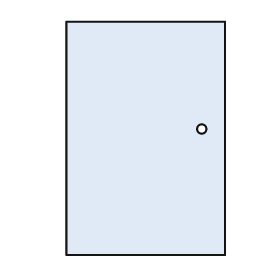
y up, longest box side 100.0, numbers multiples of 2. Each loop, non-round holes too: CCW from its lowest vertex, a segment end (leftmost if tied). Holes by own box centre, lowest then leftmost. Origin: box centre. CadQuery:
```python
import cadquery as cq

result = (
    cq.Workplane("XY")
    .moveTo(-34.0, -50.0)
    .lineTo(34.0, -50.0)
    .lineTo(34.0, 50.0)
    .lineTo(-34.0, 50.0)
    .close()
    .moveTo(24.0, 4.0)
    .circle(2.0)
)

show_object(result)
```